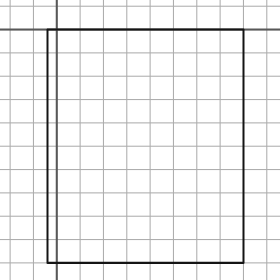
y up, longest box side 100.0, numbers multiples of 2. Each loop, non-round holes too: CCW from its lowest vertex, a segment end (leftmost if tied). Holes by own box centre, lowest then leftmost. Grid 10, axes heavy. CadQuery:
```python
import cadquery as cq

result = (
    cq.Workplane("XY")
    .moveTo(-4.0, -100.0)
    .lineTo(80.0, -100.0)
    .lineTo(80.0, 0.0)
    .lineTo(-4.0, 0.0)
    .close()
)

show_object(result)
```